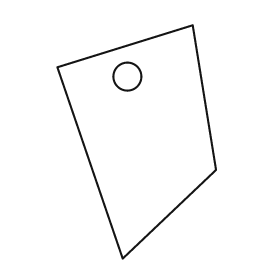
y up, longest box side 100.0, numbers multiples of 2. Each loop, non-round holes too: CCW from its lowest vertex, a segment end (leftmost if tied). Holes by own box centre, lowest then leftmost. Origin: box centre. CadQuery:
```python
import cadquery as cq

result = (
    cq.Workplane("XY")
    .moveTo(-6.0, -50.0)
    .lineTo(34.0, -12.0)
    .lineTo(24.0, 50.0)
    .lineTo(-34.0, 32.0)
    .close()
    .moveTo(-4.0, 28.0)
    .circle(6.0)
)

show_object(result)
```